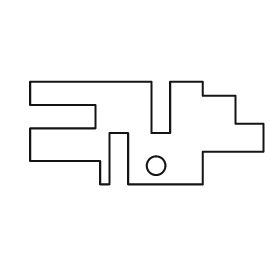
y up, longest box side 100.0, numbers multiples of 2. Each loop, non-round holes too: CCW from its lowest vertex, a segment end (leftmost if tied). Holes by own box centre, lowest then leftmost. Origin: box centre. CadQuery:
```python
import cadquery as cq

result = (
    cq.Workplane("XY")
    .moveTo(-20.0, -22.0)
    .lineTo(-16.0, -22.0)
    .lineTo(-16.0, 0.0)
    .lineTo(-8.0, 0.0)
    .lineTo(-8.0, -22.0)
    .lineTo(24.0, -22.0)
    .lineTo(24.0, -8.0)
    .lineTo(50.0, -8.0)
    .lineTo(50.0, 4.0)
    .lineTo(38.0, 4.0)
    .lineTo(38.0, 16.0)
    .lineTo(24.0, 16.0)
    .lineTo(24.0, 22.0)
    .lineTo(10.0, 22.0)
    .lineTo(10.0, 0.0)
    .lineTo(2.0, 0.0)
    .lineTo(2.0, 22.0)
    .lineTo(-50.0, 22.0)
    .lineTo(-50.0, 12.0)
    .lineTo(-22.0, 12.0)
    .lineTo(-22.0, 2.0)
    .lineTo(-50.0, 2.0)
    .lineTo(-50.0, -12.0)
    .lineTo(-20.0, -12.0)
    .close()
    .moveTo(4.0, -14.0)
    .circle(4.0)
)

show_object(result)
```